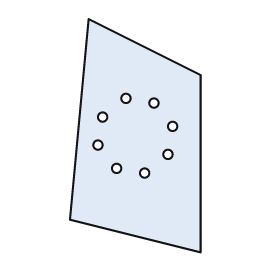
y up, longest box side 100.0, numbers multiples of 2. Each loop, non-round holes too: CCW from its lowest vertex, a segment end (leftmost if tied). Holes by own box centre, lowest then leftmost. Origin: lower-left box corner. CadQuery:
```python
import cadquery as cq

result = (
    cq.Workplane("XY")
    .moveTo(56.0, 0.0)
    .lineTo(56.0, 76.0)
    .lineTo(8.0, 100.0)
    .lineTo(0.0, 14.0)
    .close()
    .moveTo(32.0, 34.0)
    .circle(2.0)
    .moveTo(20.0, 36.0)
    .circle(2.0)
    .moveTo(42.0, 42.0)
    .circle(2.0)
    .moveTo(12.0, 46.0)
    .circle(2.0)
    .moveTo(44.0, 54.0)
    .circle(2.0)
    .moveTo(14.0, 58.0)
    .circle(2.0)
    .moveTo(36.0, 64.0)
    .circle(2.0)
    .moveTo(24.0, 66.0)
    .circle(2.0)
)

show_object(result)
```